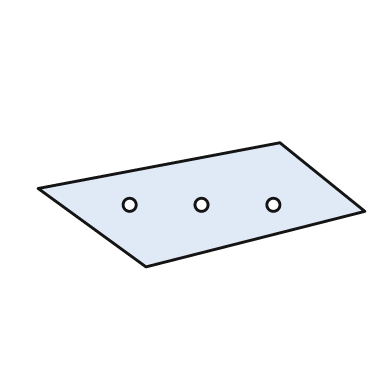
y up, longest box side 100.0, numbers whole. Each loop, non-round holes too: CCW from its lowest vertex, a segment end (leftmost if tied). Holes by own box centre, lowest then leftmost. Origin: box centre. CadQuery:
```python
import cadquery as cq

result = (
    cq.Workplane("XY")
    .moveTo(-17.0, -19.0)
    .lineTo(50.0, -2.0)
    .lineTo(24.0, 19.0)
    .lineTo(-50.0, 5.0)
    .close()
    .moveTo(-22.0, 0.0)
    .circle(2.0)
    .moveTo(0.0, 0.0)
    .circle(2.0)
    .moveTo(22.0, 0.0)
    .circle(2.0)
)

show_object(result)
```